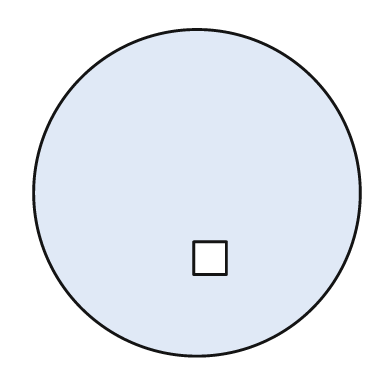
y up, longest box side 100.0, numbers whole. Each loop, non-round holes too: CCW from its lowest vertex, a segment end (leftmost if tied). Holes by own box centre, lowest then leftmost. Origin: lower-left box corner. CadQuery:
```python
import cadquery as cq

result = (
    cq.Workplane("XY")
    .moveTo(50.0, 50.0)
    .circle(50.0)
    .moveTo(49.0, 25.0)
    .lineTo(59.0, 25.0)
    .lineTo(59.0, 35.0)
    .lineTo(49.0, 35.0)
    .close()
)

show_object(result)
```